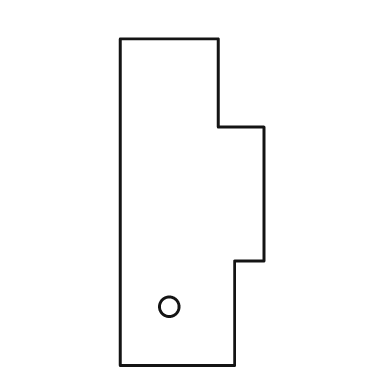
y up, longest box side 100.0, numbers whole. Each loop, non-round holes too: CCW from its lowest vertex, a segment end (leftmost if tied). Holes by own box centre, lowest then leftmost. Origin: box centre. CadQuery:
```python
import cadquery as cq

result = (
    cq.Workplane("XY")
    .moveTo(-22.0, -50.0)
    .lineTo(13.0, -50.0)
    .lineTo(13.0, -18.0)
    .lineTo(22.0, -18.0)
    .lineTo(22.0, 23.0)
    .lineTo(8.0, 23.0)
    .lineTo(8.0, 50.0)
    .lineTo(-22.0, 50.0)
    .close()
    .moveTo(-7.0, -32.0)
    .circle(3.0)
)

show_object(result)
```